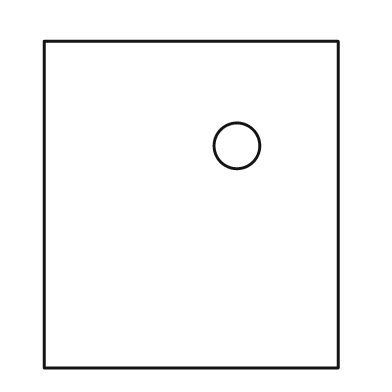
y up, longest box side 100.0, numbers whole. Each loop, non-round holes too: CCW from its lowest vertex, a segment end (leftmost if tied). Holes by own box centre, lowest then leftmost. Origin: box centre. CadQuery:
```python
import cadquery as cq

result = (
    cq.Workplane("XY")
    .moveTo(-45.0, -50.0)
    .lineTo(45.0, -50.0)
    .lineTo(45.0, 50.0)
    .lineTo(-45.0, 50.0)
    .close()
    .moveTo(14.0, 18.0)
    .circle(7.0)
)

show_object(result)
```